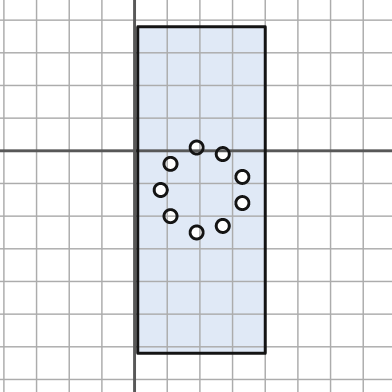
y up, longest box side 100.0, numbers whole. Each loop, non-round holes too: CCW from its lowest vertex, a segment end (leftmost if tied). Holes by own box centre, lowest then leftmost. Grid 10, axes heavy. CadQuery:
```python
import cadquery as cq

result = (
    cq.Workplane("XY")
    .moveTo(1.0, -62.0)
    .lineTo(40.0, -62.0)
    .lineTo(40.0, 38.0)
    .lineTo(1.0, 38.0)
    .close()
    .moveTo(19.0, -25.0)
    .circle(2.0)
    .moveTo(27.0, -23.0)
    .circle(2.0)
    .moveTo(11.0, -20.0)
    .circle(2.0)
    .moveTo(33.0, -16.0)
    .circle(2.0)
    .moveTo(8.0, -12.0)
    .circle(2.0)
    .moveTo(33.0, -8.0)
    .circle(2.0)
    .moveTo(11.0, -4.0)
    .circle(2.0)
    .moveTo(27.0, -1.0)
    .circle(2.0)
    .moveTo(19.0, 1.0)
    .circle(2.0)
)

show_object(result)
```